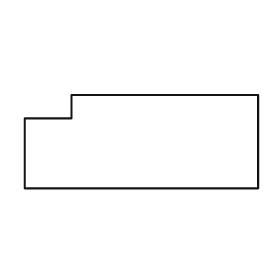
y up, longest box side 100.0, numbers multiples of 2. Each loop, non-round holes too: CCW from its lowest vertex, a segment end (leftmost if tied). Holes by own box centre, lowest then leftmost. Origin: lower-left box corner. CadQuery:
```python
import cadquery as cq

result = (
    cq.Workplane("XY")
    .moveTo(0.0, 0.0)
    .lineTo(100.0, 0.0)
    .lineTo(100.0, 40.0)
    .lineTo(20.0, 40.0)
    .lineTo(20.0, 30.0)
    .lineTo(0.0, 30.0)
    .close()
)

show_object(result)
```